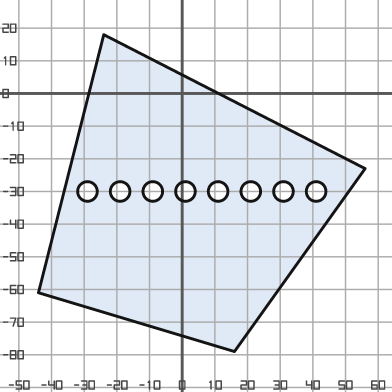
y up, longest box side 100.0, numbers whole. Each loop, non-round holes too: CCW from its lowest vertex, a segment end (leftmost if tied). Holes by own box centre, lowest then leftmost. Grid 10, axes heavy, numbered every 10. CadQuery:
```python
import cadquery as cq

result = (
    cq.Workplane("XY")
    .moveTo(16.0, -79.0)
    .lineTo(56.0, -23.0)
    .lineTo(-24.0, 18.0)
    .lineTo(-44.0, -61.0)
    .close()
    .moveTo(-29.0, -30.0)
    .circle(3.0)
    .moveTo(-19.0, -30.0)
    .circle(3.0)
    .moveTo(-9.0, -30.0)
    .circle(3.0)
    .moveTo(1.0, -30.0)
    .circle(3.0)
    .moveTo(11.0, -30.0)
    .circle(3.0)
    .moveTo(21.0, -30.0)
    .circle(3.0)
    .moveTo(31.0, -30.0)
    .circle(3.0)
    .moveTo(41.0, -30.0)
    .circle(3.0)
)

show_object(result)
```